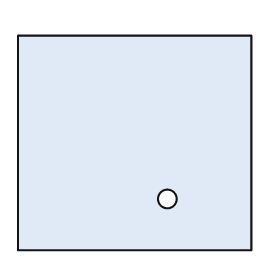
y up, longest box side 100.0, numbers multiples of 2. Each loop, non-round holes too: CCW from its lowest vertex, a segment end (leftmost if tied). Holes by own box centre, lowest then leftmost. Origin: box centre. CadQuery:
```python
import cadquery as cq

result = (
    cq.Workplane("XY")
    .moveTo(-50.0, -46.0)
    .lineTo(50.0, -46.0)
    .lineTo(50.0, 46.0)
    .lineTo(-50.0, 46.0)
    .close()
    .moveTo(14.0, -24.0)
    .circle(4.0)
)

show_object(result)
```